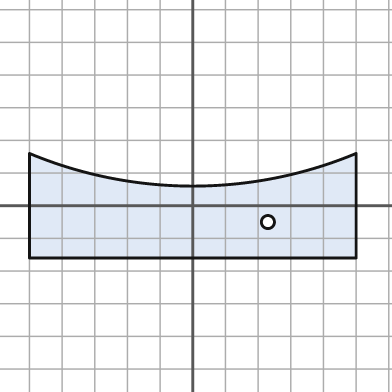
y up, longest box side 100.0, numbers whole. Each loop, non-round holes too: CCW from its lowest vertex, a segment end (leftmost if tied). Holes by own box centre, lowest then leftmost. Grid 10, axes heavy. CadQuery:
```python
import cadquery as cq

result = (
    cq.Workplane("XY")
    .moveTo(-50.0, -16.0)
    .lineTo(50.0, -16.0)
    .lineTo(50.0, 16.0)
    .threePointArc((0.0, 6.0), (-50.0, 16.0))
    .close()
    .moveTo(23.0, -5.0)
    .circle(2.0)
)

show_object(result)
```